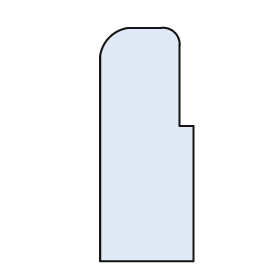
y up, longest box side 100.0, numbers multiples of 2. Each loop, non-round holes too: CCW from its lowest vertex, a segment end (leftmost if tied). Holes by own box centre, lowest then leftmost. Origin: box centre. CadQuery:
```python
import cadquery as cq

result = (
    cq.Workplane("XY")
    .moveTo(-20.0, -50.0)
    .lineTo(20.0, -50.0)
    .lineTo(20.0, 8.0)
    .lineTo(14.0, 8.0)
    .lineTo(14.0, 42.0)
    .threePointArc((12.0, 48.0), (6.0, 50.0))
    .lineTo(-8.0, 50.0)
    .threePointArc((-16.0, 46.0), (-20.0, 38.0))
    .close()
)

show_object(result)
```